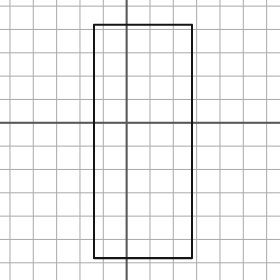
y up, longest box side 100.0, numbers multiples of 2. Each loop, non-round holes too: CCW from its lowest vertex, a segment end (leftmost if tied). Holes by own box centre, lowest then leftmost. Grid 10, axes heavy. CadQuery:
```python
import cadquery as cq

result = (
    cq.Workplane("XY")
    .moveTo(-14.0, -58.0)
    .lineTo(28.0, -58.0)
    .lineTo(28.0, 42.0)
    .lineTo(-14.0, 42.0)
    .close()
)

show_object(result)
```